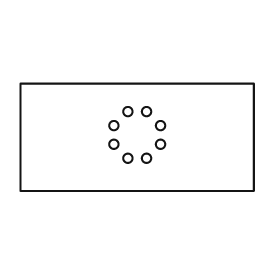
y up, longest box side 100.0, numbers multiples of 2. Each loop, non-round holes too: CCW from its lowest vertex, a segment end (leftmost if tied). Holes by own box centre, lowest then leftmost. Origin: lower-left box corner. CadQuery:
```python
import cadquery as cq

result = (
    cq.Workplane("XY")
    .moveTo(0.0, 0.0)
    .lineTo(100.0, 0.0)
    .lineTo(100.0, 46.0)
    .lineTo(0.0, 46.0)
    .close()
    .moveTo(46.0, 14.0)
    .circle(2.0)
    .moveTo(54.0, 14.0)
    .circle(2.0)
    .moveTo(40.0, 20.0)
    .circle(2.0)
    .moveTo(60.0, 20.0)
    .circle(2.0)
    .moveTo(40.0, 28.0)
    .circle(2.0)
    .moveTo(60.0, 28.0)
    .circle(2.0)
    .moveTo(46.0, 34.0)
    .circle(2.0)
    .moveTo(54.0, 34.0)
    .circle(2.0)
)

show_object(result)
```